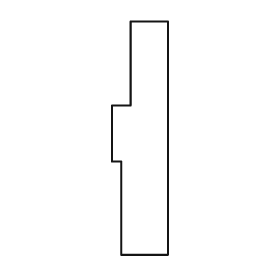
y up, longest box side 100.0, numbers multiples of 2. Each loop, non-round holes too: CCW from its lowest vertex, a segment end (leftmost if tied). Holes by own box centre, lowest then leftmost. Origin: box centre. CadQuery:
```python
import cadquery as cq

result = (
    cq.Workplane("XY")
    .moveTo(-8.0, -50.0)
    .lineTo(12.0, -50.0)
    .lineTo(12.0, 50.0)
    .lineTo(-4.0, 50.0)
    .lineTo(-4.0, 14.0)
    .lineTo(-12.0, 14.0)
    .lineTo(-12.0, -10.0)
    .lineTo(-8.0, -10.0)
    .close()
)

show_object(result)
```